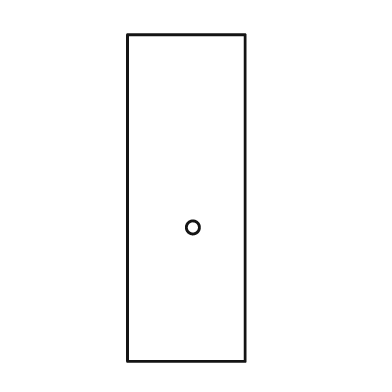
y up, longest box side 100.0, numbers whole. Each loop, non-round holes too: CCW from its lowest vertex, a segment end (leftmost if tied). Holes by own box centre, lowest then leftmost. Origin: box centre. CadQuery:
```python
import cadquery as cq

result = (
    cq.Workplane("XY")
    .moveTo(-18.0, -50.0)
    .lineTo(18.0, -50.0)
    .lineTo(18.0, 50.0)
    .lineTo(-18.0, 50.0)
    .close()
    .moveTo(2.0, -9.0)
    .circle(2.0)
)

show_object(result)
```